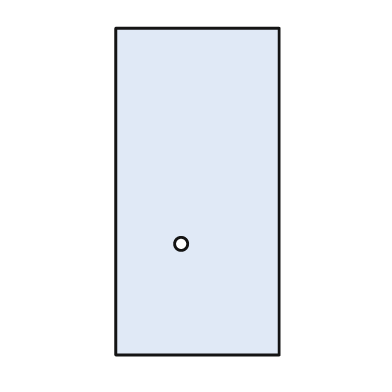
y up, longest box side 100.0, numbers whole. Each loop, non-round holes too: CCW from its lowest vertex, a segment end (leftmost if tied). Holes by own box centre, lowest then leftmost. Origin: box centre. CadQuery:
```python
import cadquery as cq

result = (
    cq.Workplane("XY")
    .moveTo(-25.0, -50.0)
    .lineTo(25.0, -50.0)
    .lineTo(25.0, 50.0)
    .lineTo(-25.0, 50.0)
    .close()
    .moveTo(-5.0, -16.0)
    .circle(2.0)
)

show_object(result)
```